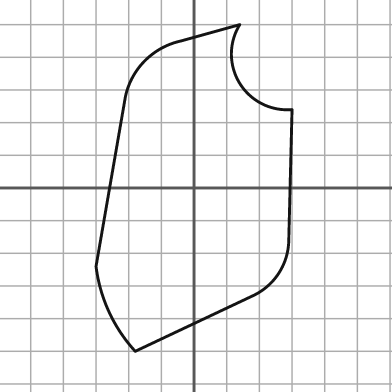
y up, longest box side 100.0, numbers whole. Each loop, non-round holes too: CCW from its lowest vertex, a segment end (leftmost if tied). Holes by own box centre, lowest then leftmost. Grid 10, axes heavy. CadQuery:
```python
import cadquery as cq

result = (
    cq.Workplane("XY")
    .moveTo(-18.0, -50.0)
    .lineTo(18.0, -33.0)
    .threePointArc((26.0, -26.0), (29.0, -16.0))
    .lineTo(30.0, 24.0)
    .threePointArc((14.0, 32.0), (14.0, 50.0))
    .lineTo(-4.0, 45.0)
    .threePointArc((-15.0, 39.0), (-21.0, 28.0))
    .lineTo(-30.0, -24.0)
    .threePointArc((-26.0, -38.0), (-18.0, -50.0))
    .close()
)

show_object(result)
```